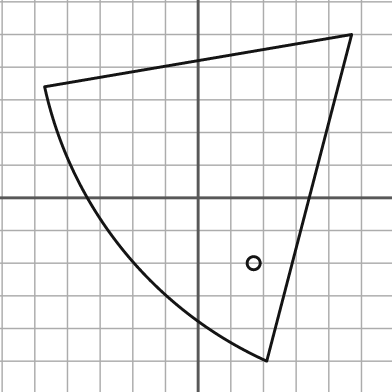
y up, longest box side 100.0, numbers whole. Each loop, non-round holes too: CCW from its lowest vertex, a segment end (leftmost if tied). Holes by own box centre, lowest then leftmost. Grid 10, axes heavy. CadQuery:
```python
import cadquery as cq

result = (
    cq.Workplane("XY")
    .moveTo(21.0, -50.0)
    .lineTo(47.0, 50.0)
    .lineTo(-47.0, 34.0)
    .threePointArc((-23.0, -16.0), (21.0, -50.0))
    .close()
    .moveTo(17.0, -20.0)
    .circle(2.0)
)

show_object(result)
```